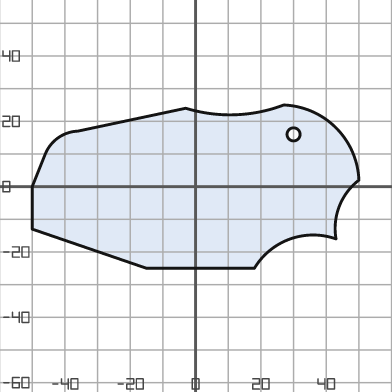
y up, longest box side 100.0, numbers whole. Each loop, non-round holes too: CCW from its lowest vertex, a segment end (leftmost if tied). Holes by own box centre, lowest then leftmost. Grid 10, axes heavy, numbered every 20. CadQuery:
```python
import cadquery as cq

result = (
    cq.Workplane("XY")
    .moveTo(-15.0, -25.0)
    .lineTo(18.0, -25.0)
    .threePointArc((29.0, -16.0), (43.0, -16.0))
    .threePointArc((44.0, -6.0), (50.0, 2.0))
    .threePointArc((43.0, 18.0), (27.0, 25.0))
    .threePointArc((12.0, 22.0), (-3.0, 24.0))
    .lineTo(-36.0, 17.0)
    .threePointArc((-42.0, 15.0), (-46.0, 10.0))
    .lineTo(-50.0, 0.0)
    .lineTo(-50.0, -13.0)
    .close()
    .moveTo(30.0, 16.0)
    .circle(2.0)
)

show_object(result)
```